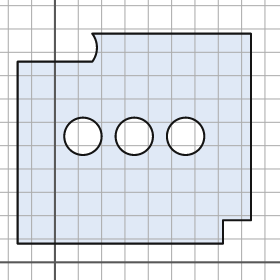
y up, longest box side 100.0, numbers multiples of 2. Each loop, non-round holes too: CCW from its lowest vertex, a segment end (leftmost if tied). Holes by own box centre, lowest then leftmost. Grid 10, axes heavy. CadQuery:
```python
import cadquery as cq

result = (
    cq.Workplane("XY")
    .moveTo(-16.0, 8.0)
    .lineTo(72.0, 8.0)
    .lineTo(72.0, 18.0)
    .lineTo(84.0, 18.0)
    .lineTo(84.0, 98.0)
    .lineTo(16.0, 98.0)
    .threePointArc((18.0, 92.0), (16.0, 86.0))
    .lineTo(-16.0, 86.0)
    .close()
    .moveTo(12.0, 54.0)
    .circle(8.0)
    .moveTo(34.0, 54.0)
    .circle(8.0)
    .moveTo(56.0, 54.0)
    .circle(8.0)
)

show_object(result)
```